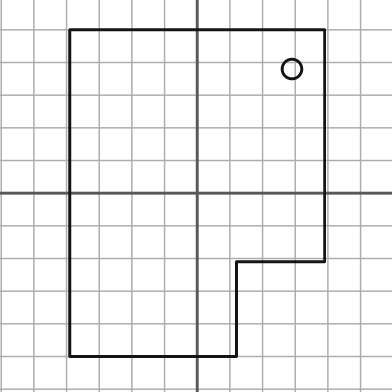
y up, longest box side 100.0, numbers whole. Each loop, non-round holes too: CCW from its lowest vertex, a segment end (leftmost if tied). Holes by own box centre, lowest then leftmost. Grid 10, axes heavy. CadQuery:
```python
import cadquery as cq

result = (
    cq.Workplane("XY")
    .moveTo(-39.0, -50.0)
    .lineTo(12.0, -50.0)
    .lineTo(12.0, -21.0)
    .lineTo(39.0, -21.0)
    .lineTo(39.0, 50.0)
    .lineTo(-39.0, 50.0)
    .close()
    .moveTo(29.0, 38.0)
    .circle(3.0)
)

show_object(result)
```